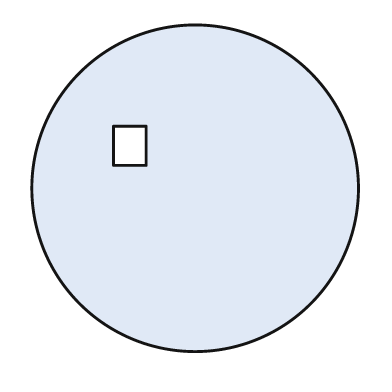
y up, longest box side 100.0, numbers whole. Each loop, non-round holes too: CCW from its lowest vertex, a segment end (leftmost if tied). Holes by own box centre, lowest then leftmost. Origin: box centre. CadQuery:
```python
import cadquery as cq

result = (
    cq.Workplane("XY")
    .moveTo(0.0, 0.0)
    .circle(50.0)
    .moveTo(-25.0, 7.0)
    .lineTo(-15.0, 7.0)
    .lineTo(-15.0, 19.0)
    .lineTo(-25.0, 19.0)
    .close()
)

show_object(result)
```